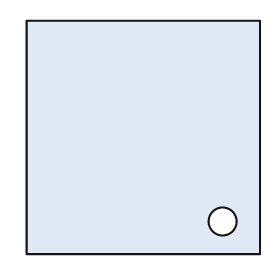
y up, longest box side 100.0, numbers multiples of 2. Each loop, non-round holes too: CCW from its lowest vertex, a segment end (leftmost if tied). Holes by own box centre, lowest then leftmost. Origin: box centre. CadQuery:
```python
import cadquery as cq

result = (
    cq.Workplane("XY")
    .moveTo(-50.0, -50.0)
    .lineTo(50.0, -50.0)
    .lineTo(50.0, 50.0)
    .lineTo(-50.0, 50.0)
    .close()
    .moveTo(34.0, -36.0)
    .circle(6.0)
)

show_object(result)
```